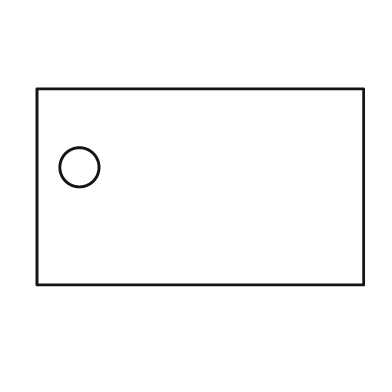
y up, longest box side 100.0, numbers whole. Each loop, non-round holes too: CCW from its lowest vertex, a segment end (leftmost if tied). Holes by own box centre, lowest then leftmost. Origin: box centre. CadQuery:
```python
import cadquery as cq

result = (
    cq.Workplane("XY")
    .moveTo(-50.0, -30.0)
    .lineTo(50.0, -30.0)
    .lineTo(50.0, 30.0)
    .lineTo(-50.0, 30.0)
    .close()
    .moveTo(-37.0, 6.0)
    .circle(6.0)
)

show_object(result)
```